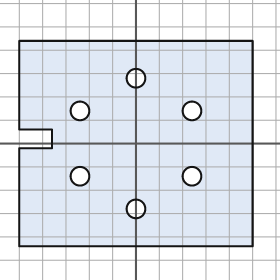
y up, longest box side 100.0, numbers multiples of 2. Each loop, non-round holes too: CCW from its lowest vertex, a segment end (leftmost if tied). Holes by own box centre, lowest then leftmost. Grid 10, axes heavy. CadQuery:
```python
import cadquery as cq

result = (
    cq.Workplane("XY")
    .moveTo(-50.0, -44.0)
    .lineTo(50.0, -44.0)
    .lineTo(50.0, 44.0)
    .lineTo(-50.0, 44.0)
    .lineTo(-50.0, 6.0)
    .lineTo(-36.0, 6.0)
    .lineTo(-36.0, -2.0)
    .lineTo(-50.0, -2.0)
    .close()
    .moveTo(0.0, -28.0)
    .circle(4.0)
    .moveTo(-24.0, -14.0)
    .circle(4.0)
    .moveTo(24.0, -14.0)
    .circle(4.0)
    .moveTo(-24.0, 14.0)
    .circle(4.0)
    .moveTo(24.0, 14.0)
    .circle(4.0)
    .moveTo(0.0, 28.0)
    .circle(4.0)
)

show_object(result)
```